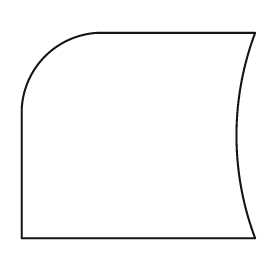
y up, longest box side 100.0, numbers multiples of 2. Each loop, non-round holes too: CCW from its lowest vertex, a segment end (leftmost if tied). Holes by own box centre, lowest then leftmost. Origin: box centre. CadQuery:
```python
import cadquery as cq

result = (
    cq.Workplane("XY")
    .moveTo(-50.0, -44.0)
    .lineTo(50.0, -44.0)
    .threePointArc((42.0, 0.0), (50.0, 44.0))
    .lineTo(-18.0, 44.0)
    .threePointArc((-40.0, 34.0), (-50.0, 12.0))
    .close()
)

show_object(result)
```